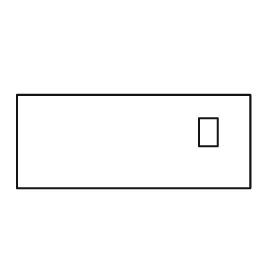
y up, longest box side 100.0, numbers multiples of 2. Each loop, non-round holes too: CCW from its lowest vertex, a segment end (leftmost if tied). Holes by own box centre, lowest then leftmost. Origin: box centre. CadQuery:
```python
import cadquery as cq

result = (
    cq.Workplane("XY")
    .moveTo(-50.0, -20.0)
    .lineTo(50.0, -20.0)
    .lineTo(50.0, 20.0)
    .lineTo(-50.0, 20.0)
    .close()
    .moveTo(28.0, -2.0)
    .lineTo(36.0, -2.0)
    .lineTo(36.0, 10.0)
    .lineTo(28.0, 10.0)
    .close()
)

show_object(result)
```